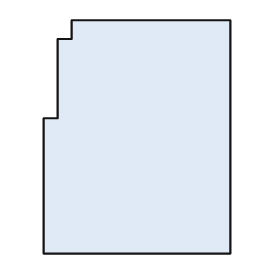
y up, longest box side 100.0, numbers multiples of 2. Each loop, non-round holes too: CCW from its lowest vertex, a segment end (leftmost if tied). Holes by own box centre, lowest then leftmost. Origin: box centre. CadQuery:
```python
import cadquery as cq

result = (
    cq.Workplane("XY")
    .moveTo(-40.0, -50.0)
    .lineTo(40.0, -50.0)
    .lineTo(40.0, 50.0)
    .lineTo(-28.0, 50.0)
    .lineTo(-28.0, 42.0)
    .lineTo(-34.0, 42.0)
    .lineTo(-34.0, 8.0)
    .lineTo(-40.0, 8.0)
    .close()
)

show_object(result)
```